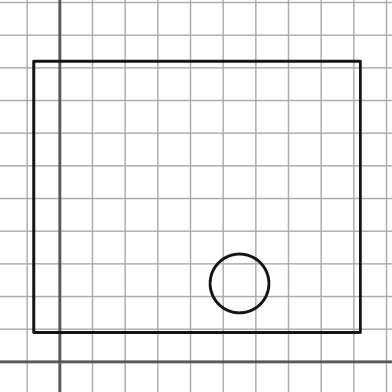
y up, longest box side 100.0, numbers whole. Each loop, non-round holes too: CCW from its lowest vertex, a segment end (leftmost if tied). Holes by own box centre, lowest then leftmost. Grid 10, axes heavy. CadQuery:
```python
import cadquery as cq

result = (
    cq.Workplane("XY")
    .moveTo(-8.0, 9.0)
    .lineTo(92.0, 9.0)
    .lineTo(92.0, 92.0)
    .lineTo(-8.0, 92.0)
    .close()
    .moveTo(55.0, 24.0)
    .circle(9.0)
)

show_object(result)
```